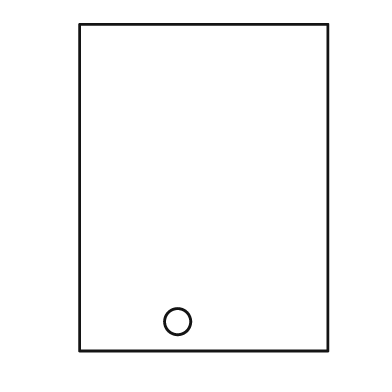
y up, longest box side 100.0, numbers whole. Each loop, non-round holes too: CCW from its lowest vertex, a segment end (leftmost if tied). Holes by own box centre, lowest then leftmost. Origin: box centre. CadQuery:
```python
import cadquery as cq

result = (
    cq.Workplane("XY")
    .moveTo(-38.0, -50.0)
    .lineTo(38.0, -50.0)
    .lineTo(38.0, 50.0)
    .lineTo(-38.0, 50.0)
    .close()
    .moveTo(-8.0, -41.0)
    .circle(4.0)
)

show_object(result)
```